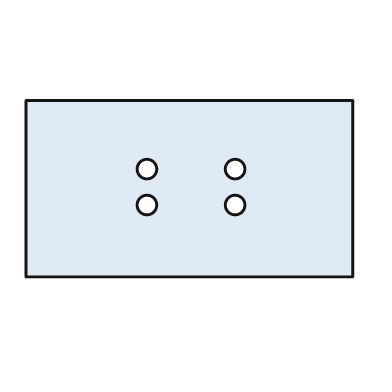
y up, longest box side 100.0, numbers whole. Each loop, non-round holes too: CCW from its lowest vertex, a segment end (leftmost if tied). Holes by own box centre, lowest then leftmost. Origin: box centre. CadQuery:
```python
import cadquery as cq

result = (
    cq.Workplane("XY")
    .moveTo(-50.0, -27.0)
    .lineTo(50.0, -27.0)
    .lineTo(50.0, 27.0)
    .lineTo(-50.0, 27.0)
    .close()
    .moveTo(-13.0, -5.0)
    .circle(3.0)
    .moveTo(14.0, -5.0)
    .circle(3.0)
    .moveTo(-13.0, 6.0)
    .circle(3.0)
    .moveTo(14.0, 6.0)
    .circle(3.0)
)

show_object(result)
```